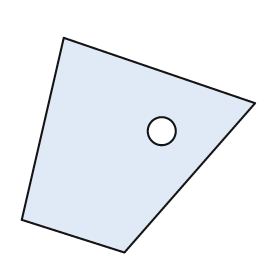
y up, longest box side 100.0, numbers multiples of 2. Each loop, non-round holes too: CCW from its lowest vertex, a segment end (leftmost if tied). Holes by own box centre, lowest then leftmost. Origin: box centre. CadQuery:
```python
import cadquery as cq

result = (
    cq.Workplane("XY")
    .moveTo(-6.0, -46.0)
    .lineTo(50.0, 18.0)
    .lineTo(-32.0, 46.0)
    .lineTo(-50.0, -32.0)
    .close()
    .moveTo(10.0, 6.0)
    .circle(6.0)
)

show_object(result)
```